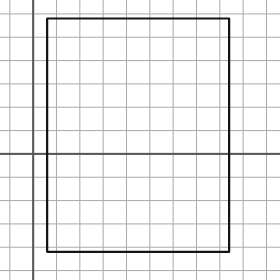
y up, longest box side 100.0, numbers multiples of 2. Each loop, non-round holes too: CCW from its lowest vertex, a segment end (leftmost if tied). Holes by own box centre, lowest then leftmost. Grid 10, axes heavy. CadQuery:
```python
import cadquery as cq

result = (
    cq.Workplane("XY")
    .moveTo(6.0, -42.0)
    .lineTo(84.0, -42.0)
    .lineTo(84.0, 58.0)
    .lineTo(6.0, 58.0)
    .close()
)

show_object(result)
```